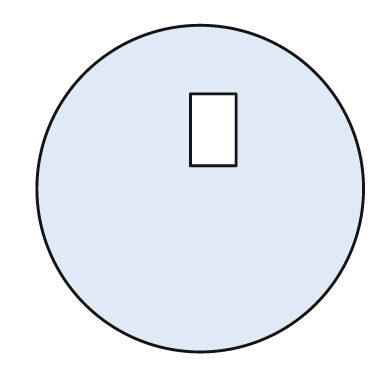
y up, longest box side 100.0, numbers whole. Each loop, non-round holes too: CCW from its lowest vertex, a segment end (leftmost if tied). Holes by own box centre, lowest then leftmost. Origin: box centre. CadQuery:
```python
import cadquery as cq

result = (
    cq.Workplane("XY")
    .moveTo(0.0, 0.0)
    .circle(50.0)
    .moveTo(-3.0, 7.0)
    .lineTo(11.0, 7.0)
    .lineTo(11.0, 29.0)
    .lineTo(-3.0, 29.0)
    .close()
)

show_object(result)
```